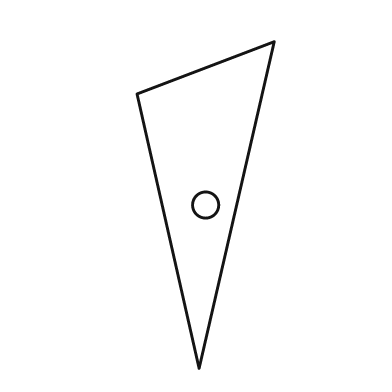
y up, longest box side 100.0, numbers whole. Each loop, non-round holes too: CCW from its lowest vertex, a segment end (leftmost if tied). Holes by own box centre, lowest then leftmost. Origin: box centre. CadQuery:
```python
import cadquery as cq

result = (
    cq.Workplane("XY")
    .moveTo(-2.0, -50.0)
    .lineTo(21.0, 50.0)
    .lineTo(-21.0, 34.0)
    .close()
    .moveTo(0.0, 0.0)
    .circle(4.0)
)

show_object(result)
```